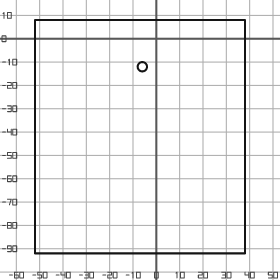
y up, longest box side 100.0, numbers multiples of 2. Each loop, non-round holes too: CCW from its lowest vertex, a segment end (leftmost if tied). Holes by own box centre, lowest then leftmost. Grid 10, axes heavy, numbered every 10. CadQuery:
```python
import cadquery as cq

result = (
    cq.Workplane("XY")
    .moveTo(-52.0, -92.0)
    .lineTo(38.0, -92.0)
    .lineTo(38.0, 8.0)
    .lineTo(-52.0, 8.0)
    .close()
    .moveTo(-6.0, -12.0)
    .circle(2.0)
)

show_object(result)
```